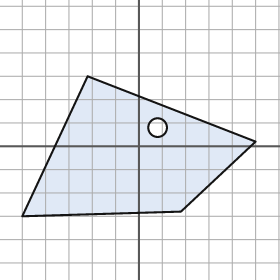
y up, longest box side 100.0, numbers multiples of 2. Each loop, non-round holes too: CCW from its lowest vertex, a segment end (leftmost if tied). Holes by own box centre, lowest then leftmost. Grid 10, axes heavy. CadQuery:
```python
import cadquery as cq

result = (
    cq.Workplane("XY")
    .moveTo(-50.0, -30.0)
    .lineTo(18.0, -28.0)
    .lineTo(50.0, 2.0)
    .lineTo(-22.0, 30.0)
    .close()
    .moveTo(8.0, 8.0)
    .circle(4.0)
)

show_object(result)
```